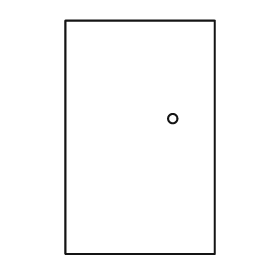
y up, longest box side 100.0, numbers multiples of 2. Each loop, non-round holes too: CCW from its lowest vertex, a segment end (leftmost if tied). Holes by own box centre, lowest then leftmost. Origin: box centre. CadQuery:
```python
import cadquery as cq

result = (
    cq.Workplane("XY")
    .moveTo(-32.0, -50.0)
    .lineTo(32.0, -50.0)
    .lineTo(32.0, 50.0)
    .lineTo(-32.0, 50.0)
    .close()
    .moveTo(14.0, 8.0)
    .circle(2.0)
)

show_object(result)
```